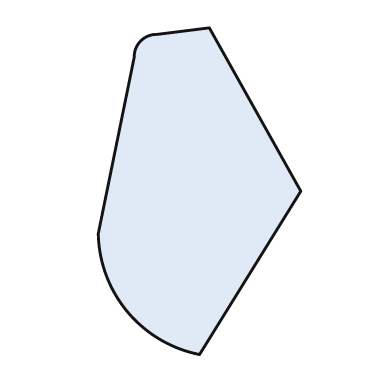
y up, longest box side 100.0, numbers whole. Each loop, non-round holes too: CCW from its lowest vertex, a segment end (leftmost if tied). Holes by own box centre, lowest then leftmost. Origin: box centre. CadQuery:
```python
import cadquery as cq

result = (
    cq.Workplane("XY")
    .moveTo(0.0, -50.0)
    .lineTo(31.0, 0.0)
    .lineTo(3.0, 50.0)
    .lineTo(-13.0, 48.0)
    .threePointArc((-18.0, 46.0), (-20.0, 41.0))
    .lineTo(-31.0, -13.0)
    .threePointArc((-22.0, -37.0), (0.0, -50.0))
    .close()
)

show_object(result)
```